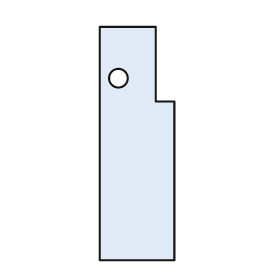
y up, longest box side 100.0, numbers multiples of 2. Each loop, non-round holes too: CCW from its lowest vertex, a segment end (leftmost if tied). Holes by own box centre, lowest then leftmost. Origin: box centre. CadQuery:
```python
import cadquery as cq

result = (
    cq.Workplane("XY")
    .moveTo(-16.0, -50.0)
    .lineTo(16.0, -50.0)
    .lineTo(16.0, 18.0)
    .lineTo(8.0, 18.0)
    .lineTo(8.0, 50.0)
    .lineTo(-16.0, 50.0)
    .close()
    .moveTo(-8.0, 28.0)
    .circle(4.0)
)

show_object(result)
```